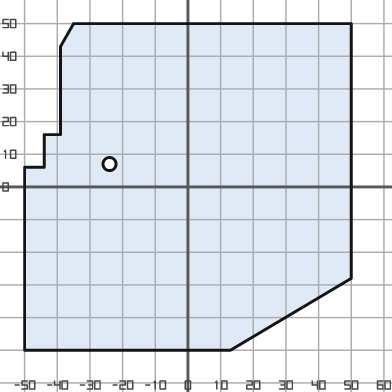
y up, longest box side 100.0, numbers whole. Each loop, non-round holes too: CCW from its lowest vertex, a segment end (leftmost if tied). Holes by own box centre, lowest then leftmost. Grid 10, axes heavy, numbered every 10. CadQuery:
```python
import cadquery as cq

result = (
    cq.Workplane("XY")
    .moveTo(-50.0, -50.0)
    .lineTo(13.0, -50.0)
    .lineTo(50.0, -28.0)
    .lineTo(50.0, 50.0)
    .lineTo(-35.0, 50.0)
    .lineTo(-39.0, 43.0)
    .lineTo(-39.0, 16.0)
    .lineTo(-44.0, 16.0)
    .lineTo(-44.0, 6.0)
    .lineTo(-50.0, 6.0)
    .close()
    .moveTo(-24.0, 7.0)
    .circle(2.0)
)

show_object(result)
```